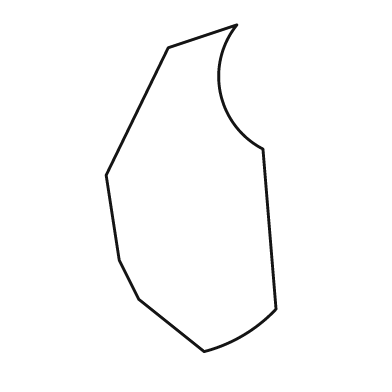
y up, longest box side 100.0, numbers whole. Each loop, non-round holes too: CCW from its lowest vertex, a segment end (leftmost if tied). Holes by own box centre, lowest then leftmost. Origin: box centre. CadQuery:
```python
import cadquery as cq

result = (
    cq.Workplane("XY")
    .moveTo(4.0, -50.0)
    .threePointArc((16.0, -45.0), (26.0, -37.0))
    .lineTo(22.0, 12.0)
    .threePointArc((9.0, 29.0), (14.0, 50.0))
    .lineTo(-7.0, 43.0)
    .lineTo(-26.0, 4.0)
    .lineTo(-22.0, -22.0)
    .lineTo(-16.0, -34.0)
    .close()
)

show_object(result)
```